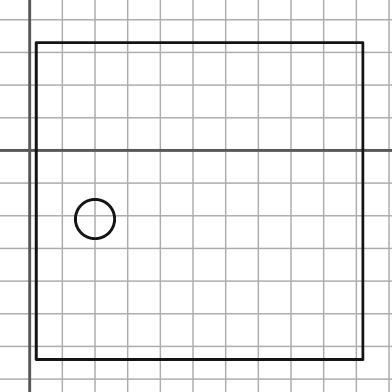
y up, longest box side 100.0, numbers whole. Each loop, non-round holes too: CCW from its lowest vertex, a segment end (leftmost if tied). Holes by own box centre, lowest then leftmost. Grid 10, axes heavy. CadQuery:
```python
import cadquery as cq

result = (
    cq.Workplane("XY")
    .moveTo(2.0, -64.0)
    .lineTo(102.0, -64.0)
    .lineTo(102.0, 33.0)
    .lineTo(2.0, 33.0)
    .close()
    .moveTo(20.0, -21.0)
    .circle(6.0)
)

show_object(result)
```